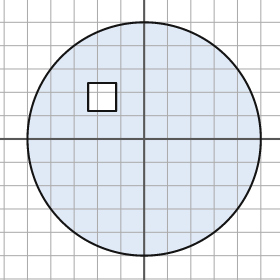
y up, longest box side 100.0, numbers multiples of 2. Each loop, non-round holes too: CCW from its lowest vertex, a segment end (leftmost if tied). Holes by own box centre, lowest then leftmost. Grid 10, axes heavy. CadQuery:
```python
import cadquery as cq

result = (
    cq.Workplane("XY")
    .moveTo(0.0, 0.0)
    .circle(50.0)
    .moveTo(-24.0, 12.0)
    .lineTo(-12.0, 12.0)
    .lineTo(-12.0, 24.0)
    .lineTo(-24.0, 24.0)
    .close()
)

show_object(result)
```